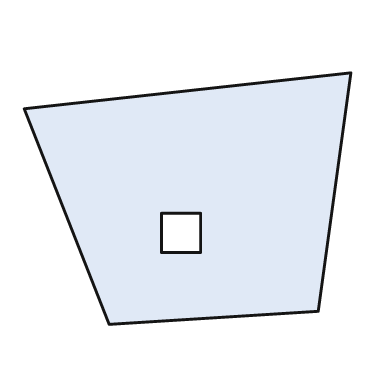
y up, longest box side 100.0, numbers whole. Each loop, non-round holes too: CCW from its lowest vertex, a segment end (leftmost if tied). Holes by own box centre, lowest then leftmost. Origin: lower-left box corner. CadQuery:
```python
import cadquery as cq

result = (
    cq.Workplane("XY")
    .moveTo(26.0, 0.0)
    .lineTo(90.0, 4.0)
    .lineTo(100.0, 77.0)
    .lineTo(0.0, 66.0)
    .close()
    .moveTo(42.0, 22.0)
    .lineTo(54.0, 22.0)
    .lineTo(54.0, 34.0)
    .lineTo(42.0, 34.0)
    .close()
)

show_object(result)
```